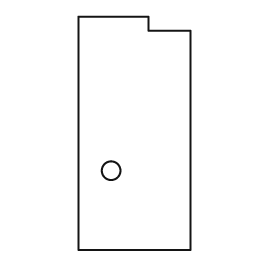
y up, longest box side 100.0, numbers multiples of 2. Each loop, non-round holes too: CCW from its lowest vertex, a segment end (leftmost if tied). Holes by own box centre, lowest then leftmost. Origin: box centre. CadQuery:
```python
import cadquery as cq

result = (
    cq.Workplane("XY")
    .moveTo(-24.0, -50.0)
    .lineTo(24.0, -50.0)
    .lineTo(24.0, 44.0)
    .lineTo(6.0, 44.0)
    .lineTo(6.0, 50.0)
    .lineTo(-24.0, 50.0)
    .close()
    .moveTo(-10.0, -16.0)
    .circle(4.0)
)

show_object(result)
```